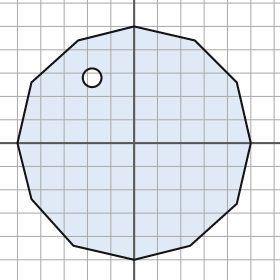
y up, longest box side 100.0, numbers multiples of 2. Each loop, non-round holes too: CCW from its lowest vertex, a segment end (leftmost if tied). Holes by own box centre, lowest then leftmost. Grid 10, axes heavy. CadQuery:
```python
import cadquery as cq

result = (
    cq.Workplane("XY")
    .moveTo(0.0, -50.0)
    .lineTo(24.0, -44.0)
    .lineTo(44.0, -26.0)
    .lineTo(50.0, 0.0)
    .lineTo(44.0, 26.0)
    .lineTo(26.0, 44.0)
    .lineTo(0.0, 50.0)
    .lineTo(-24.0, 44.0)
    .lineTo(-44.0, 26.0)
    .lineTo(-50.0, 0.0)
    .lineTo(-44.0, -24.0)
    .lineTo(-26.0, -44.0)
    .close()
    .moveTo(-18.0, 28.0)
    .circle(4.0)
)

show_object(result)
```